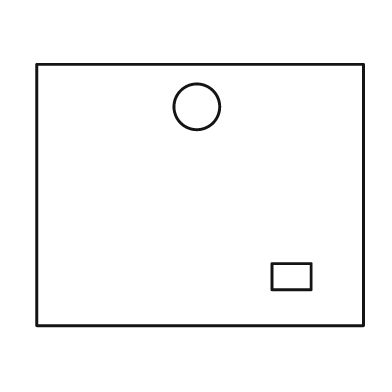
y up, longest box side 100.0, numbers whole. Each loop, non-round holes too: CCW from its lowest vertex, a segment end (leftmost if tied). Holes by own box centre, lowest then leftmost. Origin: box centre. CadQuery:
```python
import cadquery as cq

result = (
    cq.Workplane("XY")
    .moveTo(-50.0, -40.0)
    .lineTo(50.0, -40.0)
    .lineTo(50.0, 40.0)
    .lineTo(-50.0, 40.0)
    .close()
    .moveTo(22.0, -29.0)
    .lineTo(34.0, -29.0)
    .lineTo(34.0, -21.0)
    .lineTo(22.0, -21.0)
    .close()
    .moveTo(-1.0, 27.0)
    .circle(7.0)
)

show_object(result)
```